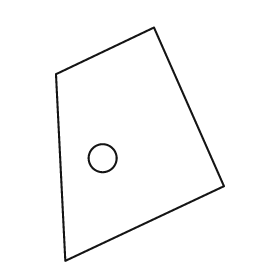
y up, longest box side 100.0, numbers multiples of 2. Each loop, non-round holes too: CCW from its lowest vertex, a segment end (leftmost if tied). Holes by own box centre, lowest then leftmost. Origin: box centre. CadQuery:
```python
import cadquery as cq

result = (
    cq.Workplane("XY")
    .moveTo(-32.0, -50.0)
    .lineTo(36.0, -18.0)
    .lineTo(6.0, 50.0)
    .lineTo(-36.0, 30.0)
    .close()
    .moveTo(-16.0, -6.0)
    .circle(6.0)
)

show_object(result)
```